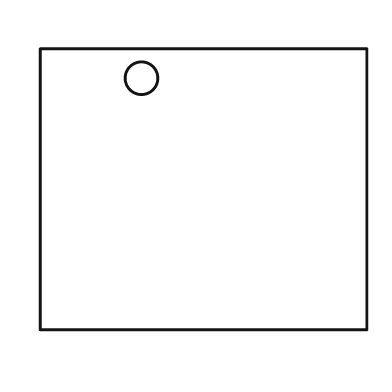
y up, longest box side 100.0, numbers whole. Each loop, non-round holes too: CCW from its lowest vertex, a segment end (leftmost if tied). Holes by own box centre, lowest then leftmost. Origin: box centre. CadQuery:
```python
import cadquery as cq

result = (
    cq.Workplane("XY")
    .moveTo(-50.0, -43.0)
    .lineTo(50.0, -43.0)
    .lineTo(50.0, 43.0)
    .lineTo(-50.0, 43.0)
    .close()
    .moveTo(-19.0, 34.0)
    .circle(5.0)
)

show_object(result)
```